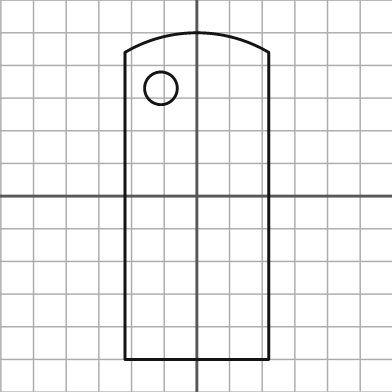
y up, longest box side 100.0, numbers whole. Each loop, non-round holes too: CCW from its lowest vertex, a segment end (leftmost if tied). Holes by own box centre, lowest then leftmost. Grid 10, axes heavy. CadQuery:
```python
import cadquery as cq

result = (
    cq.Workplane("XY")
    .moveTo(-22.0, -50.0)
    .lineTo(22.0, -50.0)
    .lineTo(22.0, 44.0)
    .threePointArc((0.0, 50.0), (-22.0, 44.0))
    .close()
    .moveTo(-11.0, 33.0)
    .circle(5.0)
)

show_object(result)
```